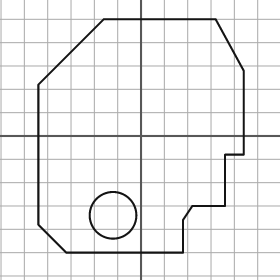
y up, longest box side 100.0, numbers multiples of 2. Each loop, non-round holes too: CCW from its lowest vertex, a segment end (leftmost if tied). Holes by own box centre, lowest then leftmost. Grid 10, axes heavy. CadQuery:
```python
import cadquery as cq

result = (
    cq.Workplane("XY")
    .moveTo(-32.0, -50.0)
    .lineTo(18.0, -50.0)
    .lineTo(18.0, -36.0)
    .lineTo(22.0, -30.0)
    .lineTo(36.0, -30.0)
    .lineTo(36.0, -8.0)
    .lineTo(44.0, -8.0)
    .lineTo(44.0, 28.0)
    .lineTo(32.0, 50.0)
    .lineTo(-16.0, 50.0)
    .lineTo(-44.0, 22.0)
    .lineTo(-44.0, -38.0)
    .close()
    .moveTo(-12.0, -34.0)
    .circle(10.0)
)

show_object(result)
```